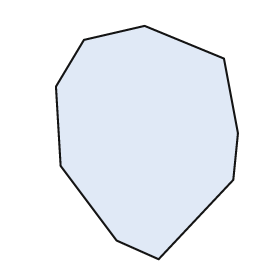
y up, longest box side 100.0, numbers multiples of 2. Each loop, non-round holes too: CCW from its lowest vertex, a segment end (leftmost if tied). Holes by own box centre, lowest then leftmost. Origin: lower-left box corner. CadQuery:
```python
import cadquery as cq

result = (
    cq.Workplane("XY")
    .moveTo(44.0, 0.0)
    .lineTo(76.0, 34.0)
    .lineTo(78.0, 54.0)
    .lineTo(72.0, 86.0)
    .lineTo(38.0, 100.0)
    .lineTo(12.0, 94.0)
    .lineTo(0.0, 74.0)
    .lineTo(2.0, 40.0)
    .lineTo(26.0, 8.0)
    .close()
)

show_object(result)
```